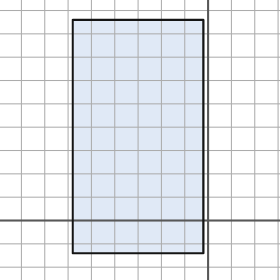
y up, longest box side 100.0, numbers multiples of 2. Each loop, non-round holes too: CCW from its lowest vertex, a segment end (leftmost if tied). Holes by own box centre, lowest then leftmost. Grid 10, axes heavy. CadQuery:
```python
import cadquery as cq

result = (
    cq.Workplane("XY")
    .moveTo(-58.0, -14.0)
    .lineTo(-2.0, -14.0)
    .lineTo(-2.0, 86.0)
    .lineTo(-58.0, 86.0)
    .close()
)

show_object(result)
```